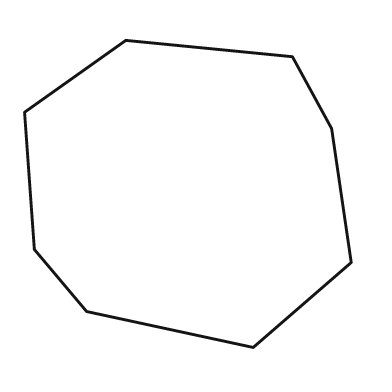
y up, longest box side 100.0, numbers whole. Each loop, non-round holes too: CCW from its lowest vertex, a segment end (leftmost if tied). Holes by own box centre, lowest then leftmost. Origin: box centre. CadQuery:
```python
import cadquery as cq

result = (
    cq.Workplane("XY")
    .moveTo(20.0, -47.0)
    .lineTo(50.0, -21.0)
    .lineTo(44.0, 20.0)
    .lineTo(32.0, 42.0)
    .lineTo(-19.0, 47.0)
    .lineTo(-50.0, 25.0)
    .lineTo(-47.0, -17.0)
    .lineTo(-31.0, -36.0)
    .close()
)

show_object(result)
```